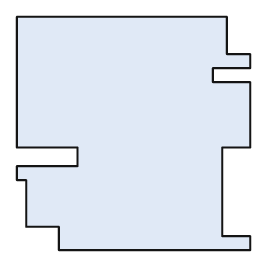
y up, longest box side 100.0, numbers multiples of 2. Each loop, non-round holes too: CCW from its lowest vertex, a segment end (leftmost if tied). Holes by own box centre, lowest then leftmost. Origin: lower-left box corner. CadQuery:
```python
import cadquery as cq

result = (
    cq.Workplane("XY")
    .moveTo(18.0, 0.0)
    .lineTo(100.0, 0.0)
    .lineTo(100.0, 6.0)
    .lineTo(88.0, 6.0)
    .lineTo(88.0, 44.0)
    .lineTo(100.0, 44.0)
    .lineTo(100.0, 72.0)
    .lineTo(84.0, 72.0)
    .lineTo(84.0, 78.0)
    .lineTo(100.0, 78.0)
    .lineTo(100.0, 84.0)
    .lineTo(90.0, 84.0)
    .lineTo(90.0, 100.0)
    .lineTo(0.0, 100.0)
    .lineTo(0.0, 44.0)
    .lineTo(26.0, 44.0)
    .lineTo(26.0, 36.0)
    .lineTo(0.0, 36.0)
    .lineTo(0.0, 30.0)
    .lineTo(4.0, 30.0)
    .lineTo(4.0, 10.0)
    .lineTo(18.0, 10.0)
    .close()
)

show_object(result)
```